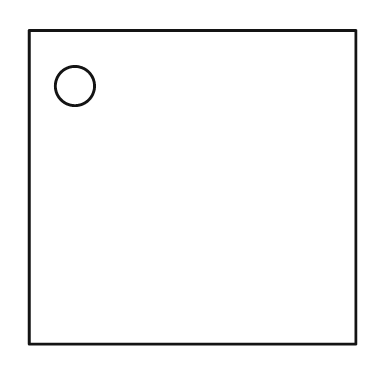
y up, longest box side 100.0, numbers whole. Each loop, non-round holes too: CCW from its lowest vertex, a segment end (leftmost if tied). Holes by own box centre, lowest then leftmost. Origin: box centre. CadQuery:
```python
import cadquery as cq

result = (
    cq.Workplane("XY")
    .moveTo(-50.0, -48.0)
    .lineTo(50.0, -48.0)
    .lineTo(50.0, 48.0)
    .lineTo(-50.0, 48.0)
    .close()
    .moveTo(-36.0, 31.0)
    .circle(6.0)
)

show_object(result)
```